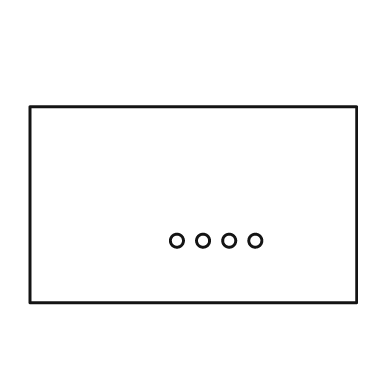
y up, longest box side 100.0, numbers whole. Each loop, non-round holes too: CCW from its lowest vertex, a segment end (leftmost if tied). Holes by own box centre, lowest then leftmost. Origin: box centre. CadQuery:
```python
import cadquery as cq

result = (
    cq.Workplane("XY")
    .moveTo(-50.0, -30.0)
    .lineTo(50.0, -30.0)
    .lineTo(50.0, 30.0)
    .lineTo(-50.0, 30.0)
    .close()
    .moveTo(-5.0, -11.0)
    .circle(2.0)
    .moveTo(3.0, -11.0)
    .circle(2.0)
    .moveTo(11.0, -11.0)
    .circle(2.0)
    .moveTo(19.0, -11.0)
    .circle(2.0)
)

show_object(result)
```